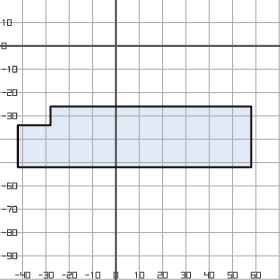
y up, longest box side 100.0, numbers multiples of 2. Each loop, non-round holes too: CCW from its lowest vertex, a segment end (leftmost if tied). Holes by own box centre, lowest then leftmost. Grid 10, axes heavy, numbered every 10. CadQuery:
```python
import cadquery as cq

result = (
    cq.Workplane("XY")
    .moveTo(-42.0, -52.0)
    .lineTo(58.0, -52.0)
    .lineTo(58.0, -26.0)
    .lineTo(-28.0, -26.0)
    .lineTo(-28.0, -34.0)
    .lineTo(-42.0, -34.0)
    .close()
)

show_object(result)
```